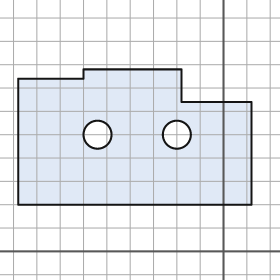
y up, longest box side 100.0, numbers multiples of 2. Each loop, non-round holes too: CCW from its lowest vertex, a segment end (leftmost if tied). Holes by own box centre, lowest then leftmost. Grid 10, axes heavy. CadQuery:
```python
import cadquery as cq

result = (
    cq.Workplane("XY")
    .moveTo(-88.0, 20.0)
    .lineTo(12.0, 20.0)
    .lineTo(12.0, 64.0)
    .lineTo(-18.0, 64.0)
    .lineTo(-18.0, 78.0)
    .lineTo(-60.0, 78.0)
    .lineTo(-60.0, 74.0)
    .lineTo(-88.0, 74.0)
    .close()
    .moveTo(-54.0, 50.0)
    .circle(6.0)
    .moveTo(-20.0, 50.0)
    .circle(6.0)
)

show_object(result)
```